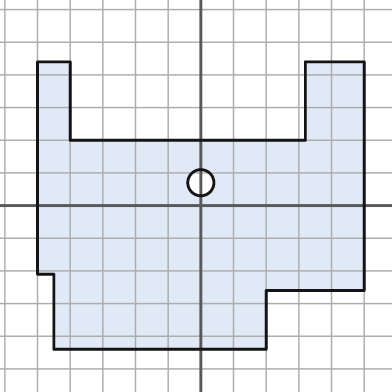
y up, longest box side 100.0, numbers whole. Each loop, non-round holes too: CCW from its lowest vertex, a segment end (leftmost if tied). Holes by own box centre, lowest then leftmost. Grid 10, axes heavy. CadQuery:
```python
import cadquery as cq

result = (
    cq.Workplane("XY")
    .moveTo(-45.0, -44.0)
    .lineTo(20.0, -44.0)
    .lineTo(20.0, -26.0)
    .lineTo(50.0, -26.0)
    .lineTo(50.0, 44.0)
    .lineTo(32.0, 44.0)
    .lineTo(32.0, 20.0)
    .lineTo(-40.0, 20.0)
    .lineTo(-40.0, 44.0)
    .lineTo(-50.0, 44.0)
    .lineTo(-50.0, -21.0)
    .lineTo(-45.0, -21.0)
    .close()
    .moveTo(0.0, 7.0)
    .circle(4.0)
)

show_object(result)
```